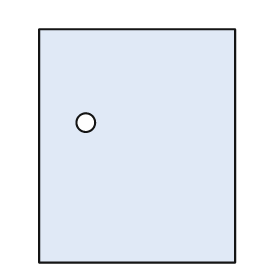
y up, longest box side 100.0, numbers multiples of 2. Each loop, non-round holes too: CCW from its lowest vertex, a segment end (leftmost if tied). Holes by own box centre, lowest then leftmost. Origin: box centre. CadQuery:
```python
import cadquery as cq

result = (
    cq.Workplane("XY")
    .moveTo(-42.0, -50.0)
    .lineTo(42.0, -50.0)
    .lineTo(42.0, 50.0)
    .lineTo(-42.0, 50.0)
    .close()
    .moveTo(-22.0, 10.0)
    .circle(4.0)
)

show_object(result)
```